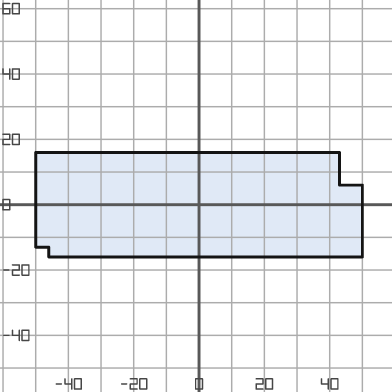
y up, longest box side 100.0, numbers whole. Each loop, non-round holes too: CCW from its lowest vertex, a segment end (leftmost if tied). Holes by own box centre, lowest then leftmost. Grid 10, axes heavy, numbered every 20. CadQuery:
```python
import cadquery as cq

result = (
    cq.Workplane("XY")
    .moveTo(-46.0, -16.0)
    .lineTo(50.0, -16.0)
    .lineTo(50.0, 6.0)
    .lineTo(43.0, 6.0)
    .lineTo(43.0, 16.0)
    .lineTo(-50.0, 16.0)
    .lineTo(-50.0, -13.0)
    .lineTo(-46.0, -13.0)
    .close()
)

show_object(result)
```